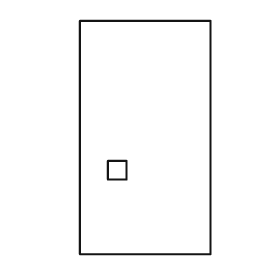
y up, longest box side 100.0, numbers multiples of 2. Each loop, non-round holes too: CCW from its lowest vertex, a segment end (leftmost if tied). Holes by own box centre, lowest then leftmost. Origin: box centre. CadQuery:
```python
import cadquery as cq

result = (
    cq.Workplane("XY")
    .moveTo(-28.0, -50.0)
    .lineTo(28.0, -50.0)
    .lineTo(28.0, 50.0)
    .lineTo(-28.0, 50.0)
    .close()
    .moveTo(-16.0, -18.0)
    .lineTo(-8.0, -18.0)
    .lineTo(-8.0, -10.0)
    .lineTo(-16.0, -10.0)
    .close()
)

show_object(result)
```